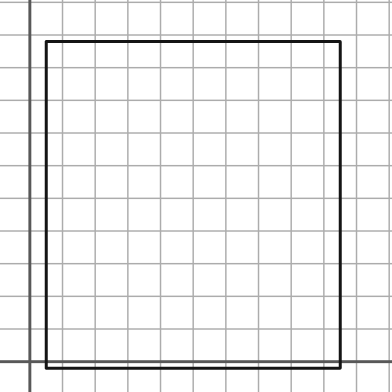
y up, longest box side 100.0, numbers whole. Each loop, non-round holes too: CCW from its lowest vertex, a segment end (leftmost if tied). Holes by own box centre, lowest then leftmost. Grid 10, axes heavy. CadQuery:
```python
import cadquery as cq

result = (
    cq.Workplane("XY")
    .moveTo(5.0, -2.0)
    .lineTo(95.0, -2.0)
    .lineTo(95.0, 98.0)
    .lineTo(5.0, 98.0)
    .close()
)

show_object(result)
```